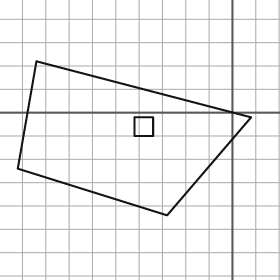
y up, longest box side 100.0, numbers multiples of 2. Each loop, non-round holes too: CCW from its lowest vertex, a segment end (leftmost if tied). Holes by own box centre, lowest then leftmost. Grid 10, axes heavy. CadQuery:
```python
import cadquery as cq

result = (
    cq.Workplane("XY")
    .moveTo(-28.0, -44.0)
    .lineTo(8.0, -2.0)
    .lineTo(-84.0, 22.0)
    .lineTo(-92.0, -24.0)
    .close()
    .moveTo(-42.0, -10.0)
    .lineTo(-34.0, -10.0)
    .lineTo(-34.0, -2.0)
    .lineTo(-42.0, -2.0)
    .close()
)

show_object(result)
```